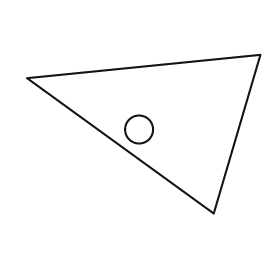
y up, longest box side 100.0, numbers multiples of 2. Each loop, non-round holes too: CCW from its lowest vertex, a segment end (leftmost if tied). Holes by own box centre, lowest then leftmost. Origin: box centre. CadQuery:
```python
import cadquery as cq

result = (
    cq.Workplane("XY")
    .moveTo(30.0, -34.0)
    .lineTo(50.0, 34.0)
    .lineTo(-50.0, 24.0)
    .close()
    .moveTo(-2.0, 2.0)
    .circle(6.0)
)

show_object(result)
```